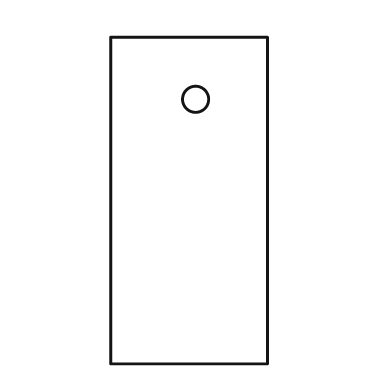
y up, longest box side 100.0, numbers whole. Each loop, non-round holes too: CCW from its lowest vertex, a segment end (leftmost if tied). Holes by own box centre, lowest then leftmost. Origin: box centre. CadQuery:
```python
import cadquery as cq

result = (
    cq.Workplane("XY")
    .moveTo(-24.0, -50.0)
    .lineTo(24.0, -50.0)
    .lineTo(24.0, 50.0)
    .lineTo(-24.0, 50.0)
    .close()
    .moveTo(2.0, 31.0)
    .circle(4.0)
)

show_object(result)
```